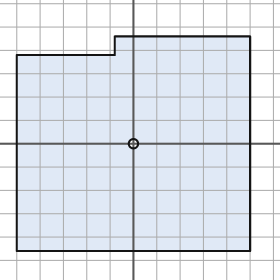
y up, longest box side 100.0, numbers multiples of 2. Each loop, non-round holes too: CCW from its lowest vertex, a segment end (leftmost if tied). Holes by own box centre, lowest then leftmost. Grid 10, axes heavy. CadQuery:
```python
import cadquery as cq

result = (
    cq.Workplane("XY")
    .moveTo(-50.0, -46.0)
    .lineTo(50.0, -46.0)
    .lineTo(50.0, 46.0)
    .lineTo(-8.0, 46.0)
    .lineTo(-8.0, 38.0)
    .lineTo(-50.0, 38.0)
    .close()
    .moveTo(0.0, 0.0)
    .circle(2.0)
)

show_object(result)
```